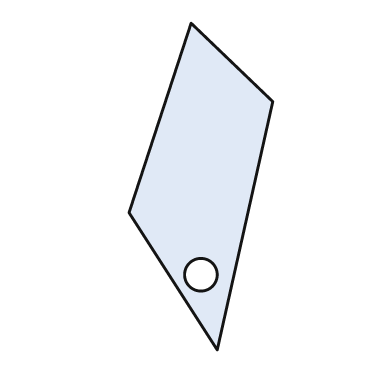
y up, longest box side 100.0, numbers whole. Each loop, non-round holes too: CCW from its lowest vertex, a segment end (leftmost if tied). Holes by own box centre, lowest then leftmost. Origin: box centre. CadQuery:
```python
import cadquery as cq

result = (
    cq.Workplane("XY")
    .moveTo(5.0, -50.0)
    .lineTo(22.0, 26.0)
    .lineTo(-3.0, 50.0)
    .lineTo(-22.0, -8.0)
    .close()
    .moveTo(0.0, -27.0)
    .circle(5.0)
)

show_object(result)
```